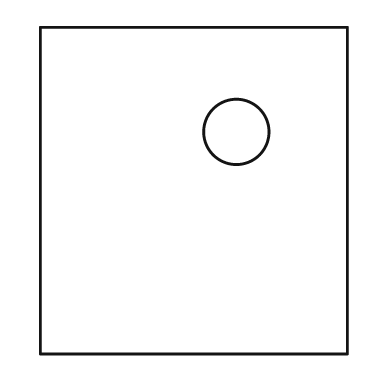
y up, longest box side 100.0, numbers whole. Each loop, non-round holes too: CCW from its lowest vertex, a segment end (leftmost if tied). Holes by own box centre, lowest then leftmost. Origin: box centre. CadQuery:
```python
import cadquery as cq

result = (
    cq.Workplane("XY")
    .moveTo(-47.0, -50.0)
    .lineTo(47.0, -50.0)
    .lineTo(47.0, 50.0)
    .lineTo(-47.0, 50.0)
    .close()
    .moveTo(13.0, 18.0)
    .circle(10.0)
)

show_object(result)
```